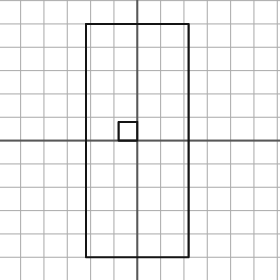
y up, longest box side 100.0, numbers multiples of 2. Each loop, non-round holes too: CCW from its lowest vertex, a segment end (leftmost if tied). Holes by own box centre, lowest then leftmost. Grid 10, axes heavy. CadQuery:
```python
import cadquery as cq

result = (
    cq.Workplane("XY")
    .moveTo(-22.0, -50.0)
    .lineTo(22.0, -50.0)
    .lineTo(22.0, 50.0)
    .lineTo(-22.0, 50.0)
    .close()
    .moveTo(-8.0, 0.0)
    .lineTo(0.0, 0.0)
    .lineTo(0.0, 8.0)
    .lineTo(-8.0, 8.0)
    .close()
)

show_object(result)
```